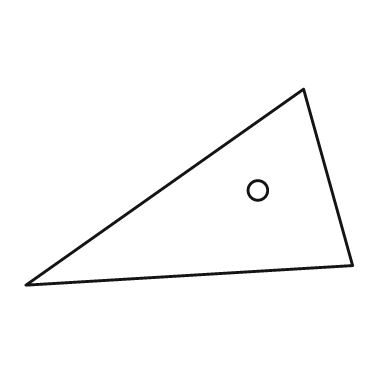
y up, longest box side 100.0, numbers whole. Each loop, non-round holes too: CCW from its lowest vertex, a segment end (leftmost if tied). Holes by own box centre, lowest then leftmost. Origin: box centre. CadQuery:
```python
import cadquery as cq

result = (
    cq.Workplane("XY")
    .moveTo(-50.0, -30.0)
    .lineTo(50.0, -24.0)
    .lineTo(35.0, 30.0)
    .close()
    .moveTo(21.0, -1.0)
    .circle(3.0)
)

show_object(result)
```